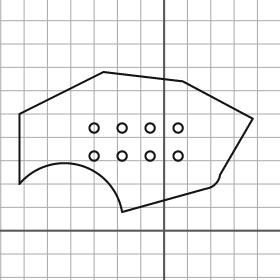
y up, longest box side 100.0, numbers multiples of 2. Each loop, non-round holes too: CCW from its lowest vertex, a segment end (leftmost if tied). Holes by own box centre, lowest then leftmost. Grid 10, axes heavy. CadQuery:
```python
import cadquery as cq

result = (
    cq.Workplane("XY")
    .moveTo(-18.0, 8.0)
    .lineTo(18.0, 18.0)
    .threePointArc((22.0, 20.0), (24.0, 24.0))
    .lineTo(38.0, 48.0)
    .lineTo(8.0, 64.0)
    .lineTo(-26.0, 68.0)
    .lineTo(-62.0, 50.0)
    .lineTo(-62.0, 20.0)
    .threePointArc((-36.0, 28.0), (-18.0, 8.0))
    .close()
    .moveTo(-30.0, 32.0)
    .circle(2.0)
    .moveTo(-18.0, 32.0)
    .circle(2.0)
    .moveTo(-6.0, 32.0)
    .circle(2.0)
    .moveTo(6.0, 32.0)
    .circle(2.0)
    .moveTo(-30.0, 44.0)
    .circle(2.0)
    .moveTo(-18.0, 44.0)
    .circle(2.0)
    .moveTo(-6.0, 44.0)
    .circle(2.0)
    .moveTo(6.0, 44.0)
    .circle(2.0)
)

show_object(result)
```